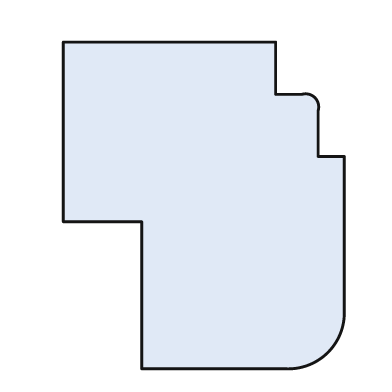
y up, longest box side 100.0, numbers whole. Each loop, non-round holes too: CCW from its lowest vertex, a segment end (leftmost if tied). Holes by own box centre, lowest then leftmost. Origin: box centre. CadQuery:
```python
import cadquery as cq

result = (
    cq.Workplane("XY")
    .moveTo(-19.0, -50.0)
    .lineTo(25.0, -50.0)
    .threePointArc((38.0, -45.0), (43.0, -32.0))
    .lineTo(43.0, 15.0)
    .lineTo(35.0, 15.0)
    .lineTo(35.0, 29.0)
    .threePointArc((34.0, 33.0), (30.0, 34.0))
    .lineTo(22.0, 34.0)
    .lineTo(22.0, 50.0)
    .lineTo(-43.0, 50.0)
    .lineTo(-43.0, -5.0)
    .lineTo(-19.0, -5.0)
    .close()
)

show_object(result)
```